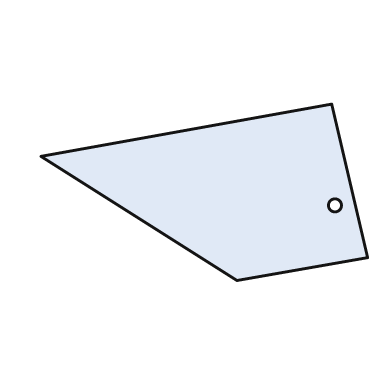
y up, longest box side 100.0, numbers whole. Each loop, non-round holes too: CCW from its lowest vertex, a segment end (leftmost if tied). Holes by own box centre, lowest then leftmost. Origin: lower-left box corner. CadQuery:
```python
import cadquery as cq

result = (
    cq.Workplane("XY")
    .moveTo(60.0, 0.0)
    .lineTo(100.0, 7.0)
    .lineTo(89.0, 54.0)
    .lineTo(0.0, 38.0)
    .close()
    .moveTo(90.0, 23.0)
    .circle(2.0)
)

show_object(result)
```